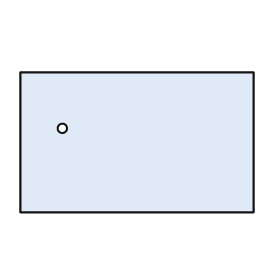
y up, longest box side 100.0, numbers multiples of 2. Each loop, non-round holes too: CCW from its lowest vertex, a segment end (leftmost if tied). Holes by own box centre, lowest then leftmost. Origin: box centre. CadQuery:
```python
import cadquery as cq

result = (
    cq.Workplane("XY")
    .moveTo(-50.0, -30.0)
    .lineTo(50.0, -30.0)
    .lineTo(50.0, 30.0)
    .lineTo(-50.0, 30.0)
    .close()
    .moveTo(-32.0, 6.0)
    .circle(2.0)
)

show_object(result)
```